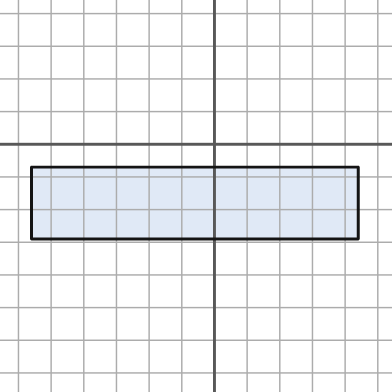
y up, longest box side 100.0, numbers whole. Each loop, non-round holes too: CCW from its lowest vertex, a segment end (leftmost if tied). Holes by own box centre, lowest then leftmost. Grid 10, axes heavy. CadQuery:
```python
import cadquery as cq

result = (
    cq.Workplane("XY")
    .moveTo(-56.0, -29.0)
    .lineTo(44.0, -29.0)
    .lineTo(44.0, -7.0)
    .lineTo(-56.0, -7.0)
    .close()
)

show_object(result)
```